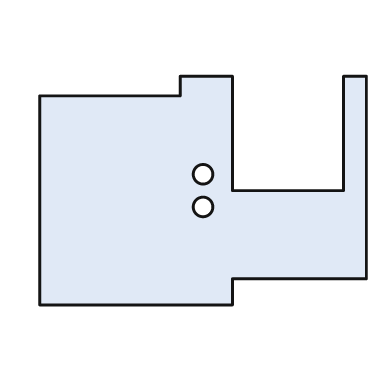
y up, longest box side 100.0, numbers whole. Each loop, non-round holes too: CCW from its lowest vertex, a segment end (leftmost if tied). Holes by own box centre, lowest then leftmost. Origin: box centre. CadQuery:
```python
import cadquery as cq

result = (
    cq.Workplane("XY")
    .moveTo(-50.0, -35.0)
    .lineTo(9.0, -35.0)
    .lineTo(9.0, -27.0)
    .lineTo(50.0, -27.0)
    .lineTo(50.0, 35.0)
    .lineTo(43.0, 35.0)
    .lineTo(43.0, 0.0)
    .lineTo(9.0, 0.0)
    .lineTo(9.0, 35.0)
    .lineTo(-7.0, 35.0)
    .lineTo(-7.0, 29.0)
    .lineTo(-50.0, 29.0)
    .close()
    .moveTo(0.0, -5.0)
    .circle(3.0)
    .moveTo(0.0, 5.0)
    .circle(3.0)
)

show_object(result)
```